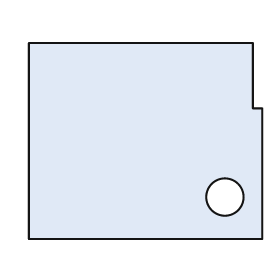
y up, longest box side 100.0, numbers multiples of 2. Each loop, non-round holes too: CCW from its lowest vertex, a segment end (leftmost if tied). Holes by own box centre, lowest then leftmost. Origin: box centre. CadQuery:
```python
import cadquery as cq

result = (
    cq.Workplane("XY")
    .moveTo(-50.0, -42.0)
    .lineTo(50.0, -42.0)
    .lineTo(50.0, 14.0)
    .lineTo(46.0, 14.0)
    .lineTo(46.0, 42.0)
    .lineTo(-50.0, 42.0)
    .close()
    .moveTo(34.0, -24.0)
    .circle(8.0)
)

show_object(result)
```